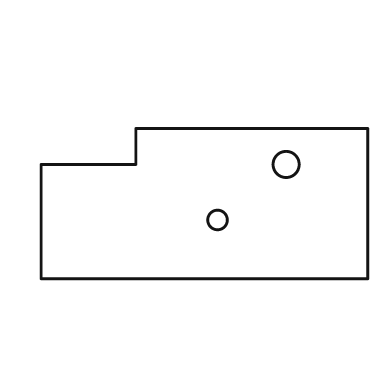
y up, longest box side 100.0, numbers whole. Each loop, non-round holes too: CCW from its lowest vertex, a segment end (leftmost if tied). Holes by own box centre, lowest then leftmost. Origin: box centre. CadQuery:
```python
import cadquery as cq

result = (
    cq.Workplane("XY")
    .moveTo(-50.0, -23.0)
    .lineTo(50.0, -23.0)
    .lineTo(50.0, 23.0)
    .lineTo(-21.0, 23.0)
    .lineTo(-21.0, 12.0)
    .lineTo(-50.0, 12.0)
    .close()
    .moveTo(4.0, -5.0)
    .circle(3.0)
    .moveTo(25.0, 12.0)
    .circle(4.0)
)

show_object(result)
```